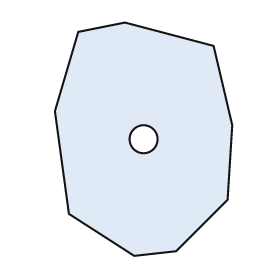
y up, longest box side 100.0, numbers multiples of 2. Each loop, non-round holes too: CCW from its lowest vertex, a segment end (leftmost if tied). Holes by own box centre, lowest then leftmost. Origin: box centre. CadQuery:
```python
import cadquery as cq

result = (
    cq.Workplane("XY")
    .moveTo(-4.0, -50.0)
    .lineTo(14.0, -48.0)
    .lineTo(36.0, -26.0)
    .lineTo(38.0, 6.0)
    .lineTo(30.0, 40.0)
    .lineTo(-8.0, 50.0)
    .lineTo(-28.0, 46.0)
    .lineTo(-38.0, 12.0)
    .lineTo(-32.0, -32.0)
    .close()
    .moveTo(0.0, 0.0)
    .circle(6.0)
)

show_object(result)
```